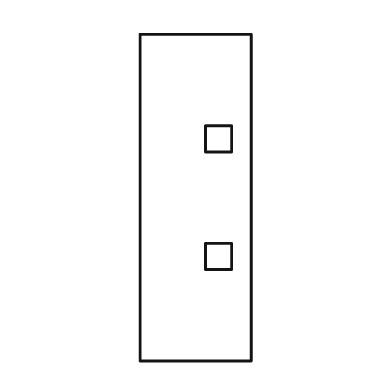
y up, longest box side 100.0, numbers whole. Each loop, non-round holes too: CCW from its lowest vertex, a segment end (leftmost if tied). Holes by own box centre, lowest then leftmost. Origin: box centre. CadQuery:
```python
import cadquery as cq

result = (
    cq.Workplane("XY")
    .moveTo(-17.0, -50.0)
    .lineTo(17.0, -50.0)
    .lineTo(17.0, 50.0)
    .lineTo(-17.0, 50.0)
    .close()
    .moveTo(3.0, -22.0)
    .lineTo(11.0, -22.0)
    .lineTo(11.0, -14.0)
    .lineTo(3.0, -14.0)
    .close()
    .moveTo(3.0, 14.0)
    .lineTo(11.0, 14.0)
    .lineTo(11.0, 22.0)
    .lineTo(3.0, 22.0)
    .close()
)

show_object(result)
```